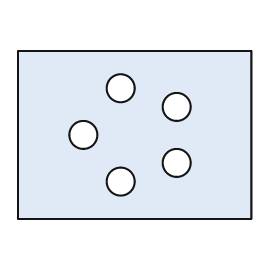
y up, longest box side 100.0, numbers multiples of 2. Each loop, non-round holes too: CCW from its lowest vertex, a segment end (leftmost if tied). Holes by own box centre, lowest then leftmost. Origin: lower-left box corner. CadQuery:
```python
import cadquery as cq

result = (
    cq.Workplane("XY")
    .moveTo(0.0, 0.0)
    .lineTo(100.0, 0.0)
    .lineTo(100.0, 72.0)
    .lineTo(0.0, 72.0)
    .close()
    .moveTo(44.0, 16.0)
    .circle(6.0)
    .moveTo(68.0, 24.0)
    .circle(6.0)
    .moveTo(28.0, 36.0)
    .circle(6.0)
    .moveTo(68.0, 48.0)
    .circle(6.0)
    .moveTo(44.0, 56.0)
    .circle(6.0)
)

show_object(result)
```